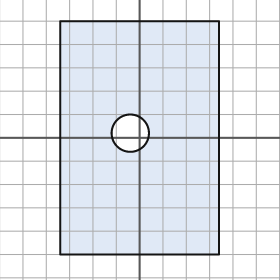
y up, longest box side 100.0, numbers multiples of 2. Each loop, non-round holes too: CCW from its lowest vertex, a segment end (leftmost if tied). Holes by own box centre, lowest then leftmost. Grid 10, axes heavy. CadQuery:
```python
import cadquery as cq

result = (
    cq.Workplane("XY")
    .moveTo(-34.0, -50.0)
    .lineTo(34.0, -50.0)
    .lineTo(34.0, 50.0)
    .lineTo(-34.0, 50.0)
    .close()
    .moveTo(-4.0, 2.0)
    .circle(8.0)
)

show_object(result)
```